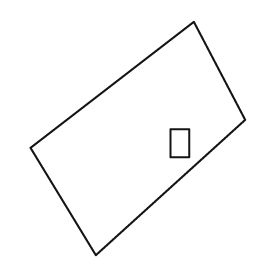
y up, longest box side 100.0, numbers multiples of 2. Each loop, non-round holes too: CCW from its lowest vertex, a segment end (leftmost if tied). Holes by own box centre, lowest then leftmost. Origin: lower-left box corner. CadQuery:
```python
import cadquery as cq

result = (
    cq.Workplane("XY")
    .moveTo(28.0, 0.0)
    .lineTo(92.0, 58.0)
    .lineTo(70.0, 100.0)
    .lineTo(0.0, 46.0)
    .close()
    .moveTo(60.0, 42.0)
    .lineTo(68.0, 42.0)
    .lineTo(68.0, 54.0)
    .lineTo(60.0, 54.0)
    .close()
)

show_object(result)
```